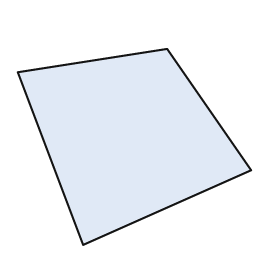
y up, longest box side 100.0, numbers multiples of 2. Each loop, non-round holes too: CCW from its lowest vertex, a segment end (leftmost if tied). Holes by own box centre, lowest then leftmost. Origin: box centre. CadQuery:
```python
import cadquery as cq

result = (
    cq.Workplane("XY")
    .moveTo(-22.0, -42.0)
    .lineTo(50.0, -10.0)
    .lineTo(14.0, 42.0)
    .lineTo(-50.0, 32.0)
    .close()
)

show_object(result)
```